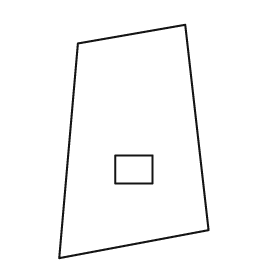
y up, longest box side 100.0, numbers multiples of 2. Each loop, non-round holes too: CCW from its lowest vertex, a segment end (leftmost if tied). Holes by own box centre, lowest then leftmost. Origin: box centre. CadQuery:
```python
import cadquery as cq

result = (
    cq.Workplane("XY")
    .moveTo(-32.0, -50.0)
    .lineTo(32.0, -38.0)
    .lineTo(22.0, 50.0)
    .lineTo(-24.0, 42.0)
    .close()
    .moveTo(-8.0, -18.0)
    .lineTo(8.0, -18.0)
    .lineTo(8.0, -6.0)
    .lineTo(-8.0, -6.0)
    .close()
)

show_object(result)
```